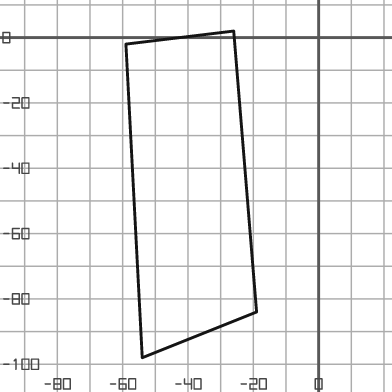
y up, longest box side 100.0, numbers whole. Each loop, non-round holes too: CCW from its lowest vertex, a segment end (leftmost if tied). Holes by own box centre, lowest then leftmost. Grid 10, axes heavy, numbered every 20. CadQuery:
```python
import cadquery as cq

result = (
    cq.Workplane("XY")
    .moveTo(-54.0, -98.0)
    .lineTo(-19.0, -84.0)
    .lineTo(-26.0, 2.0)
    .lineTo(-59.0, -2.0)
    .close()
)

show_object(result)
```